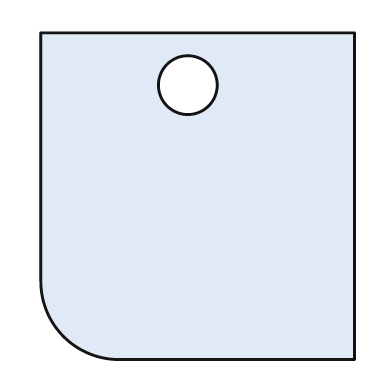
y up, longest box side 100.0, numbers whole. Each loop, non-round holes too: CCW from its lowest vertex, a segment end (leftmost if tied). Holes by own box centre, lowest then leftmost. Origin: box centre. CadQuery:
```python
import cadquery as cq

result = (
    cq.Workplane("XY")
    .moveTo(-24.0, -50.0)
    .lineTo(48.0, -50.0)
    .lineTo(48.0, 50.0)
    .lineTo(-48.0, 50.0)
    .lineTo(-48.0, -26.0)
    .threePointArc((-41.0, -43.0), (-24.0, -50.0))
    .close()
    .moveTo(-3.0, 34.0)
    .circle(9.0)
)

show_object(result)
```